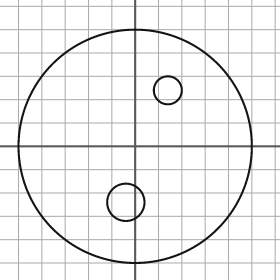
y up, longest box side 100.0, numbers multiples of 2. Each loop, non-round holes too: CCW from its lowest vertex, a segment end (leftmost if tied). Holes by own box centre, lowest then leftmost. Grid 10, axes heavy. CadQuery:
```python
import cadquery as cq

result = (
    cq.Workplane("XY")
    .moveTo(0.0, 0.0)
    .circle(50.0)
    .moveTo(-4.0, -24.0)
    .circle(8.0)
    .moveTo(14.0, 24.0)
    .circle(6.0)
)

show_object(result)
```